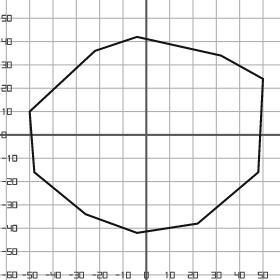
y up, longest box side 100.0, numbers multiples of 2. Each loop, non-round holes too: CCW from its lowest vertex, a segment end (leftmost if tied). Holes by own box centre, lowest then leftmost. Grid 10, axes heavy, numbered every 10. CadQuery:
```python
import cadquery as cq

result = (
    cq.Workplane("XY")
    .moveTo(-4.0, -42.0)
    .lineTo(22.0, -38.0)
    .lineTo(48.0, -16.0)
    .lineTo(50.0, 24.0)
    .lineTo(32.0, 34.0)
    .lineTo(-4.0, 42.0)
    .lineTo(-22.0, 36.0)
    .lineTo(-50.0, 10.0)
    .lineTo(-48.0, -16.0)
    .lineTo(-26.0, -34.0)
    .close()
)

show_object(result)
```